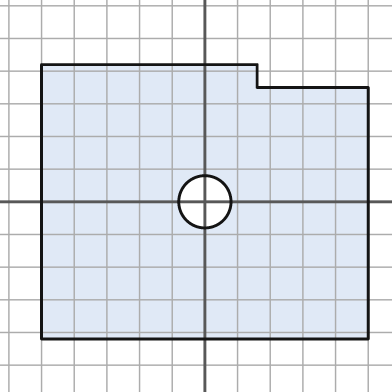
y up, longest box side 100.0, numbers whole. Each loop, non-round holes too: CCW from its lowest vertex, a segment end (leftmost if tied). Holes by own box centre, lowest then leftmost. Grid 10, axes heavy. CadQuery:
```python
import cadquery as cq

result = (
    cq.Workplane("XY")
    .moveTo(-50.0, -42.0)
    .lineTo(50.0, -42.0)
    .lineTo(50.0, 35.0)
    .lineTo(16.0, 35.0)
    .lineTo(16.0, 42.0)
    .lineTo(-50.0, 42.0)
    .close()
    .moveTo(0.0, 0.0)
    .circle(8.0)
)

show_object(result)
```